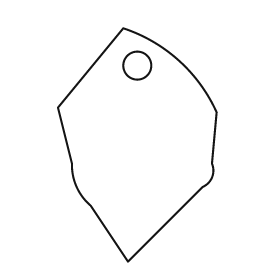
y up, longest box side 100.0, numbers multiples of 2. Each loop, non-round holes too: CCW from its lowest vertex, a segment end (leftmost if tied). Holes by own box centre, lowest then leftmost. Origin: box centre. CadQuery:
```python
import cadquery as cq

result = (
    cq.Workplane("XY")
    .moveTo(-4.0, -50.0)
    .lineTo(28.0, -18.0)
    .threePointArc((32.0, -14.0), (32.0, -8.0))
    .lineTo(34.0, 14.0)
    .threePointArc((18.0, 36.0), (-6.0, 50.0))
    .lineTo(-34.0, 16.0)
    .lineTo(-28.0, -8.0)
    .threePointArc((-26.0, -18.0), (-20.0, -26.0))
    .close()
    .moveTo(0.0, 34.0)
    .circle(6.0)
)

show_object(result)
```